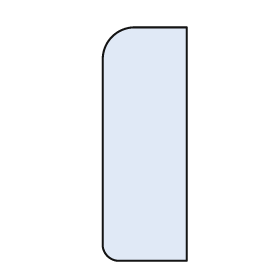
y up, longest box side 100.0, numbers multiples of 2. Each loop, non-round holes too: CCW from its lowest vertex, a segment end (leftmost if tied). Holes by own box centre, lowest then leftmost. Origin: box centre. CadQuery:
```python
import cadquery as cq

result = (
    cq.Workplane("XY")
    .moveTo(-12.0, -50.0)
    .lineTo(18.0, -50.0)
    .lineTo(18.0, 50.0)
    .lineTo(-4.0, 50.0)
    .threePointArc((-14.0, 46.0), (-18.0, 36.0))
    .lineTo(-18.0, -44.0)
    .threePointArc((-16.0, -48.0), (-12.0, -50.0))
    .close()
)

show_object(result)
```